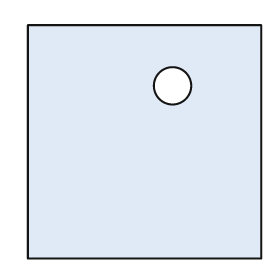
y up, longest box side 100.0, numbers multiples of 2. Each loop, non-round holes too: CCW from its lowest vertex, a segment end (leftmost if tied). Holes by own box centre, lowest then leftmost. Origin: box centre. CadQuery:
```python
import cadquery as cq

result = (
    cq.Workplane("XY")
    .moveTo(-50.0, -50.0)
    .lineTo(50.0, -50.0)
    .lineTo(50.0, 50.0)
    .lineTo(-50.0, 50.0)
    .close()
    .moveTo(12.0, 24.0)
    .circle(8.0)
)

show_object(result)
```